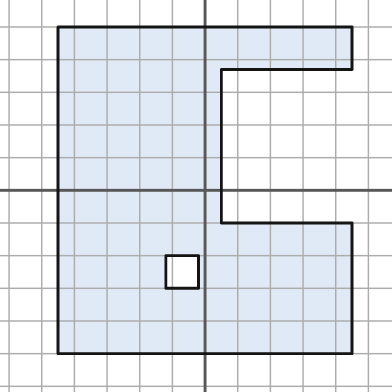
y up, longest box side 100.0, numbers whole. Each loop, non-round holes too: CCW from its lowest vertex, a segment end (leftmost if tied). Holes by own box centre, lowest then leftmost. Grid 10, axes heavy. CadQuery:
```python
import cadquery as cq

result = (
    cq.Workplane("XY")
    .moveTo(-45.0, -50.0)
    .lineTo(45.0, -50.0)
    .lineTo(45.0, -10.0)
    .lineTo(5.0, -10.0)
    .lineTo(5.0, 37.0)
    .lineTo(45.0, 37.0)
    .lineTo(45.0, 50.0)
    .lineTo(-45.0, 50.0)
    .close()
    .moveTo(-12.0, -30.0)
    .lineTo(-2.0, -30.0)
    .lineTo(-2.0, -20.0)
    .lineTo(-12.0, -20.0)
    .close()
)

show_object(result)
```